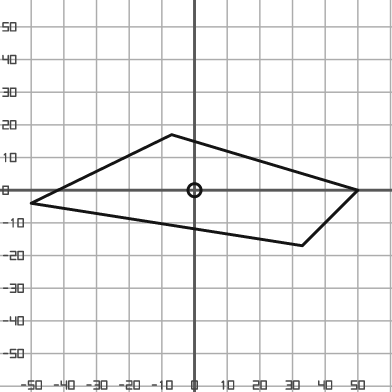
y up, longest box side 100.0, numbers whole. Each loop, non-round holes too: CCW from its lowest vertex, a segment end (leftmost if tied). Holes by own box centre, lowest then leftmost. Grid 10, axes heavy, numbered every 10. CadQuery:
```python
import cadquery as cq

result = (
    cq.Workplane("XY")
    .moveTo(33.0, -17.0)
    .lineTo(50.0, 0.0)
    .lineTo(-7.0, 17.0)
    .lineTo(-50.0, -4.0)
    .close()
    .moveTo(0.0, 0.0)
    .circle(2.0)
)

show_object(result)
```